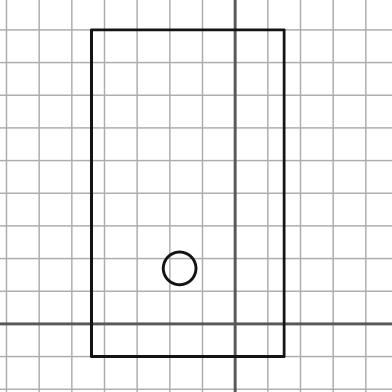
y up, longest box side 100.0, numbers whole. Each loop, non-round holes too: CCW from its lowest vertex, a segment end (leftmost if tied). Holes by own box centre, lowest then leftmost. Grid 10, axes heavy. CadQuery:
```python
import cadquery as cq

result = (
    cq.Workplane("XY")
    .moveTo(-44.0, -10.0)
    .lineTo(15.0, -10.0)
    .lineTo(15.0, 90.0)
    .lineTo(-44.0, 90.0)
    .close()
    .moveTo(-17.0, 17.0)
    .circle(5.0)
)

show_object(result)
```